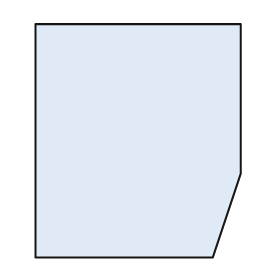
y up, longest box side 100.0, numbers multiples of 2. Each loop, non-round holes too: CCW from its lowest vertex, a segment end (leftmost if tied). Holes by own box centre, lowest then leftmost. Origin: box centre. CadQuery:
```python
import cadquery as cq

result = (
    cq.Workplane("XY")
    .moveTo(-44.0, -50.0)
    .lineTo(32.0, -50.0)
    .lineTo(44.0, -14.0)
    .lineTo(44.0, 50.0)
    .lineTo(-44.0, 50.0)
    .close()
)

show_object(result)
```